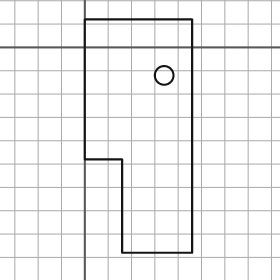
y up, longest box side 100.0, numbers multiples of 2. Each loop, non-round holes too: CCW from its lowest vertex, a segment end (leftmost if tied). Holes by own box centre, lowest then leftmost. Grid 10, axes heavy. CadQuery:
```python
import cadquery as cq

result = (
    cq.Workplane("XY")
    .moveTo(16.0, -88.0)
    .lineTo(46.0, -88.0)
    .lineTo(46.0, 12.0)
    .lineTo(0.0, 12.0)
    .lineTo(0.0, -48.0)
    .lineTo(16.0, -48.0)
    .close()
    .moveTo(34.0, -12.0)
    .circle(4.0)
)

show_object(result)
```